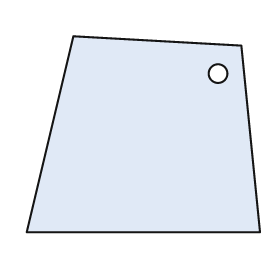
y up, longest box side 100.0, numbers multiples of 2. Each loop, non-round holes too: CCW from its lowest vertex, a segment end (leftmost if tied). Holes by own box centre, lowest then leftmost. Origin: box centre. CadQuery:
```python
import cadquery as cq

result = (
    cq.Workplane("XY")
    .moveTo(-50.0, -42.0)
    .lineTo(50.0, -42.0)
    .lineTo(42.0, 38.0)
    .lineTo(-30.0, 42.0)
    .close()
    .moveTo(32.0, 26.0)
    .circle(4.0)
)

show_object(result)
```